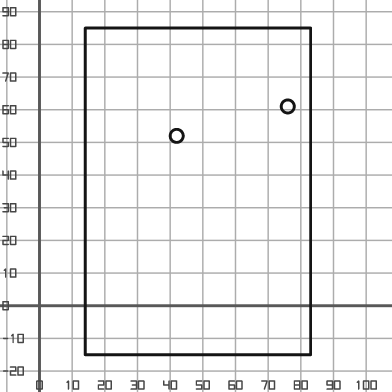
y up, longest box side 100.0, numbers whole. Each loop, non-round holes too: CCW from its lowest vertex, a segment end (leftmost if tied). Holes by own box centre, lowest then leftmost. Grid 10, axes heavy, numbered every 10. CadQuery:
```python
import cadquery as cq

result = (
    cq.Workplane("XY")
    .moveTo(14.0, -15.0)
    .lineTo(83.0, -15.0)
    .lineTo(83.0, 85.0)
    .lineTo(14.0, 85.0)
    .close()
    .moveTo(42.0, 52.0)
    .circle(2.0)
    .moveTo(76.0, 61.0)
    .circle(2.0)
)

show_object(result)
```